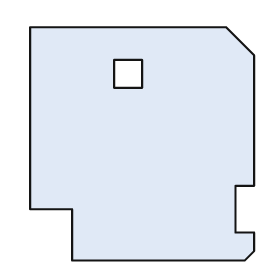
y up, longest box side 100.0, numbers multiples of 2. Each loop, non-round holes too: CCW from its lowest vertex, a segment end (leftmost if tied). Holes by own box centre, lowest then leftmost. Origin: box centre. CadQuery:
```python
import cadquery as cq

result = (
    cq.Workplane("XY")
    .moveTo(-30.0, -50.0)
    .lineTo(44.0, -50.0)
    .lineTo(48.0, -46.0)
    .lineTo(48.0, -38.0)
    .lineTo(40.0, -38.0)
    .lineTo(40.0, -18.0)
    .lineTo(48.0, -18.0)
    .lineTo(48.0, 38.0)
    .lineTo(36.0, 50.0)
    .lineTo(-48.0, 50.0)
    .lineTo(-48.0, -28.0)
    .lineTo(-30.0, -28.0)
    .close()
    .moveTo(-12.0, 24.0)
    .lineTo(0.0, 24.0)
    .lineTo(0.0, 36.0)
    .lineTo(-12.0, 36.0)
    .close()
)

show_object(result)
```